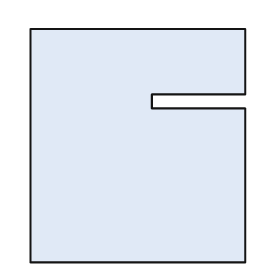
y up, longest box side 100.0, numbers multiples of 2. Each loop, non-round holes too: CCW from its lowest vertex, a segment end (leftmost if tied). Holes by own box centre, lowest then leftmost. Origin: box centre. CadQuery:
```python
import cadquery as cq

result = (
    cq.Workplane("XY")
    .moveTo(-46.0, -50.0)
    .lineTo(46.0, -50.0)
    .lineTo(46.0, 16.0)
    .lineTo(6.0, 16.0)
    .lineTo(6.0, 22.0)
    .lineTo(46.0, 22.0)
    .lineTo(46.0, 50.0)
    .lineTo(-46.0, 50.0)
    .close()
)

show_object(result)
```